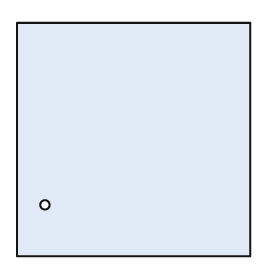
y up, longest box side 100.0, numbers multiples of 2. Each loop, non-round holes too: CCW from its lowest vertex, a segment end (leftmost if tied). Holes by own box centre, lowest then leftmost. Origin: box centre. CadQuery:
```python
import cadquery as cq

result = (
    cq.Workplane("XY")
    .moveTo(-50.0, -50.0)
    .lineTo(50.0, -50.0)
    .lineTo(50.0, 50.0)
    .lineTo(-50.0, 50.0)
    .close()
    .moveTo(-38.0, -28.0)
    .circle(2.0)
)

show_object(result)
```